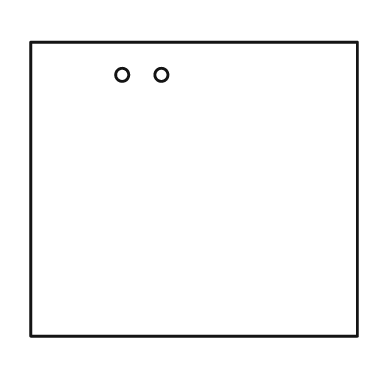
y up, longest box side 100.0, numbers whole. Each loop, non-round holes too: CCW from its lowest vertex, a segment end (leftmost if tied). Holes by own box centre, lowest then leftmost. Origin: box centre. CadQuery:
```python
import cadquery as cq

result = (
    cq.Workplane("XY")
    .moveTo(-50.0, -45.0)
    .lineTo(50.0, -45.0)
    .lineTo(50.0, 45.0)
    .lineTo(-50.0, 45.0)
    .close()
    .moveTo(-22.0, 35.0)
    .circle(2.0)
    .moveTo(-10.0, 35.0)
    .circle(2.0)
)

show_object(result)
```